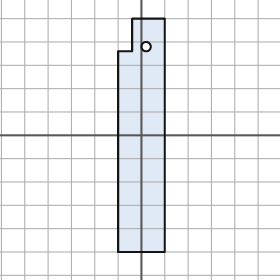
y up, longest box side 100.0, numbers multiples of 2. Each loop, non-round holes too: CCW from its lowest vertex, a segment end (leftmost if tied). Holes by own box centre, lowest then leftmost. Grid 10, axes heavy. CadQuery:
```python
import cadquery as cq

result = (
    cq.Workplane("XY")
    .moveTo(-10.0, -50.0)
    .lineTo(10.0, -50.0)
    .lineTo(10.0, 50.0)
    .lineTo(-4.0, 50.0)
    .lineTo(-4.0, 36.0)
    .lineTo(-10.0, 36.0)
    .close()
    .moveTo(2.0, 38.0)
    .circle(2.0)
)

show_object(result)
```